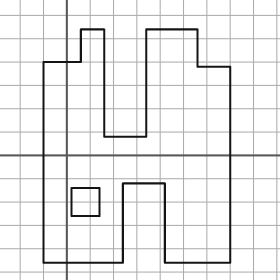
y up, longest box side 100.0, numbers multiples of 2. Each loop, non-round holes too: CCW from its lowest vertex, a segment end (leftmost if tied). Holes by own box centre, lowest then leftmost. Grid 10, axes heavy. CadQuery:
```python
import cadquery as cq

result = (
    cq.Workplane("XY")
    .moveTo(-10.0, -46.0)
    .lineTo(24.0, -46.0)
    .lineTo(24.0, -12.0)
    .lineTo(42.0, -12.0)
    .lineTo(42.0, -46.0)
    .lineTo(70.0, -46.0)
    .lineTo(70.0, 38.0)
    .lineTo(56.0, 38.0)
    .lineTo(56.0, 54.0)
    .lineTo(34.0, 54.0)
    .lineTo(34.0, 8.0)
    .lineTo(16.0, 8.0)
    .lineTo(16.0, 54.0)
    .lineTo(6.0, 54.0)
    .lineTo(6.0, 40.0)
    .lineTo(-10.0, 40.0)
    .close()
    .moveTo(2.0, -26.0)
    .lineTo(14.0, -26.0)
    .lineTo(14.0, -14.0)
    .lineTo(2.0, -14.0)
    .close()
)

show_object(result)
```